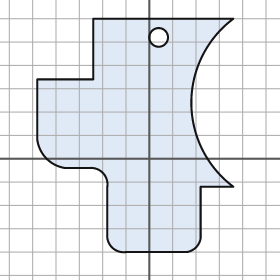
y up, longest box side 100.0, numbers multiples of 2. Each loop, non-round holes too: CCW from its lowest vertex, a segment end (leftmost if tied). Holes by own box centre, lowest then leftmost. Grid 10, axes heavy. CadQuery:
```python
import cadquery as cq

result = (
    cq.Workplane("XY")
    .moveTo(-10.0, -40.0)
    .lineTo(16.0, -40.0)
    .threePointArc((20.0, -38.0), (22.0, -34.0))
    .lineTo(22.0, -12.0)
    .lineTo(36.0, -12.0)
    .threePointArc((18.0, 24.0), (36.0, 60.0))
    .lineTo(-24.0, 60.0)
    .lineTo(-24.0, 34.0)
    .lineTo(-48.0, 34.0)
    .lineTo(-48.0, 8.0)
    .threePointArc((-44.0, 0.0), (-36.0, -4.0))
    .lineTo(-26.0, -4.0)
    .threePointArc((-20.0, -6.0), (-18.0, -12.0))
    .lineTo(-18.0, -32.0)
    .threePointArc((-16.0, -38.0), (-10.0, -40.0))
    .close()
    .moveTo(4.0, 52.0)
    .circle(4.0)
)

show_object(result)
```